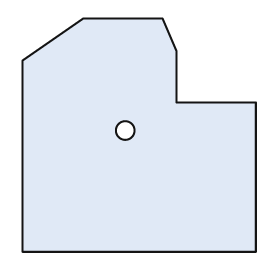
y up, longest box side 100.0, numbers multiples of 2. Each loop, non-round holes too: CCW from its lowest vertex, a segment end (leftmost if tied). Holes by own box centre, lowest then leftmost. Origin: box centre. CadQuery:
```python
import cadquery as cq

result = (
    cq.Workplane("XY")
    .moveTo(-50.0, -50.0)
    .lineTo(50.0, -50.0)
    .lineTo(50.0, 14.0)
    .lineTo(16.0, 14.0)
    .lineTo(16.0, 36.0)
    .lineTo(10.0, 50.0)
    .lineTo(-24.0, 50.0)
    .lineTo(-50.0, 32.0)
    .close()
    .moveTo(-6.0, 2.0)
    .circle(4.0)
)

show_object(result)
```